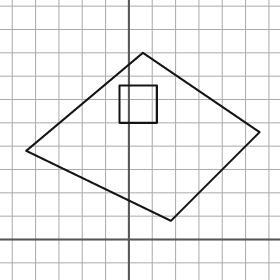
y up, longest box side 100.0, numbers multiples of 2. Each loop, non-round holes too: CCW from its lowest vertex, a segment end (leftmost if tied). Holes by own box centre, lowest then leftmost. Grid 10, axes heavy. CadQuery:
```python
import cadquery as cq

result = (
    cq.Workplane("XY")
    .moveTo(18.0, 8.0)
    .lineTo(56.0, 46.0)
    .lineTo(6.0, 80.0)
    .lineTo(-44.0, 38.0)
    .close()
    .moveTo(-4.0, 50.0)
    .lineTo(12.0, 50.0)
    .lineTo(12.0, 66.0)
    .lineTo(-4.0, 66.0)
    .close()
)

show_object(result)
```